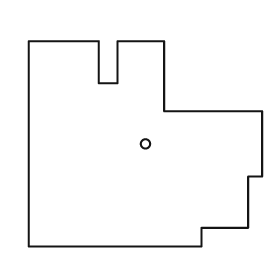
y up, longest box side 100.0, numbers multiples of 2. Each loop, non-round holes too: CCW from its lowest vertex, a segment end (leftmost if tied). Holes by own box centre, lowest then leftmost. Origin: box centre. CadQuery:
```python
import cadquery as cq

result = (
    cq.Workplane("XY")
    .moveTo(-50.0, -44.0)
    .lineTo(24.0, -44.0)
    .lineTo(24.0, -36.0)
    .lineTo(44.0, -36.0)
    .lineTo(44.0, -14.0)
    .lineTo(50.0, -14.0)
    .lineTo(50.0, 14.0)
    .lineTo(8.0, 14.0)
    .lineTo(8.0, 44.0)
    .lineTo(-12.0, 44.0)
    .lineTo(-12.0, 26.0)
    .lineTo(-20.0, 26.0)
    .lineTo(-20.0, 44.0)
    .lineTo(-50.0, 44.0)
    .close()
    .moveTo(0.0, 0.0)
    .circle(2.0)
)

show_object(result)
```